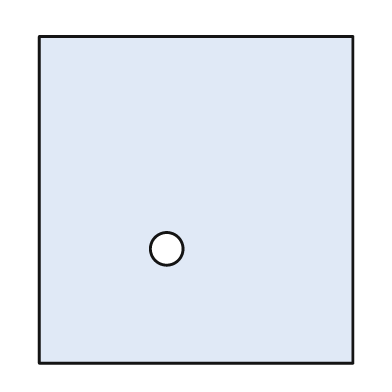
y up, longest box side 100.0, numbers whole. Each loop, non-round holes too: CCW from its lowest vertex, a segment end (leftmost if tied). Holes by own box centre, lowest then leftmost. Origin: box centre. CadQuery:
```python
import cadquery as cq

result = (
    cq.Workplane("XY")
    .moveTo(-48.0, -50.0)
    .lineTo(48.0, -50.0)
    .lineTo(48.0, 50.0)
    .lineTo(-48.0, 50.0)
    .close()
    .moveTo(-9.0, -15.0)
    .circle(5.0)
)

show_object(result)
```